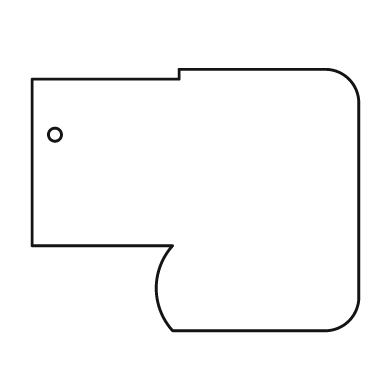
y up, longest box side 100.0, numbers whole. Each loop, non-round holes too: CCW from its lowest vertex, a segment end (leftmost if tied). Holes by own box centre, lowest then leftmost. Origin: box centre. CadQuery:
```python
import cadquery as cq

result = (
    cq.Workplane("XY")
    .moveTo(-7.0, -40.0)
    .lineTo(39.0, -40.0)
    .threePointArc((47.0, -37.0), (50.0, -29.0))
    .lineTo(50.0, 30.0)
    .threePointArc((47.0, 37.0), (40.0, 40.0))
    .lineTo(-5.0, 40.0)
    .lineTo(-5.0, 37.0)
    .lineTo(-50.0, 37.0)
    .lineTo(-50.0, -14.0)
    .lineTo(-7.0, -14.0)
    .threePointArc((-12.0, -27.0), (-7.0, -40.0))
    .close()
    .moveTo(-43.0, 20.0)
    .circle(2.0)
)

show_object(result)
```